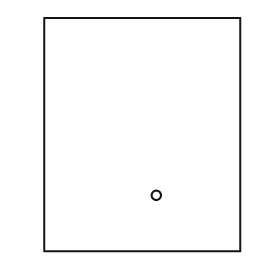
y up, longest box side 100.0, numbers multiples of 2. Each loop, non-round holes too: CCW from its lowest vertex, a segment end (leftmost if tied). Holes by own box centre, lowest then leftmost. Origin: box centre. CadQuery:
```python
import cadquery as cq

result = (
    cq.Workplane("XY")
    .moveTo(-42.0, -50.0)
    .lineTo(42.0, -50.0)
    .lineTo(42.0, 50.0)
    .lineTo(-42.0, 50.0)
    .close()
    .moveTo(6.0, -26.0)
    .circle(2.0)
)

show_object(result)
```